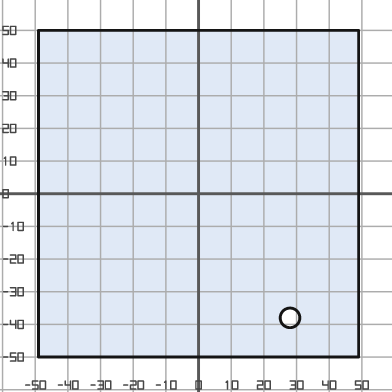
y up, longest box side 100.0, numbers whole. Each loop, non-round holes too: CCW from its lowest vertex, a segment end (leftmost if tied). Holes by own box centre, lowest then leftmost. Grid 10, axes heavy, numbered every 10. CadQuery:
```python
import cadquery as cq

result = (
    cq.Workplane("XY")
    .moveTo(-49.0, -50.0)
    .lineTo(49.0, -50.0)
    .lineTo(49.0, 50.0)
    .lineTo(-49.0, 50.0)
    .close()
    .moveTo(28.0, -38.0)
    .circle(3.0)
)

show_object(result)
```